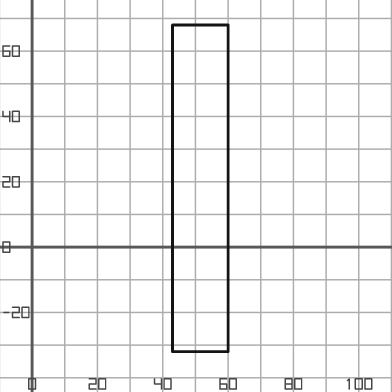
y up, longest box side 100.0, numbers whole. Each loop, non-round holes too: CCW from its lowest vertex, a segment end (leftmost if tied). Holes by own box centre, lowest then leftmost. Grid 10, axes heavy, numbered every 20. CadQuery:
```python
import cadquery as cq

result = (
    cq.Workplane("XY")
    .moveTo(43.0, -32.0)
    .lineTo(60.0, -32.0)
    .lineTo(60.0, 68.0)
    .lineTo(43.0, 68.0)
    .close()
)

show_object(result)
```